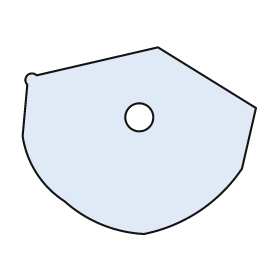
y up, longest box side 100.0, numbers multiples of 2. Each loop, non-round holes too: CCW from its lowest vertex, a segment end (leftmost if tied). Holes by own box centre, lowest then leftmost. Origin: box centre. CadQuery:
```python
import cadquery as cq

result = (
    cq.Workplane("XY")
    .moveTo(2.0, -40.0)
    .threePointArc((26.0, -30.0), (44.0, -12.0))
    .lineTo(50.0, 14.0)
    .lineTo(8.0, 40.0)
    .lineTo(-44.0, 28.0)
    .threePointArc((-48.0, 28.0), (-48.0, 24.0))
    .lineTo(-50.0, 2.0)
    .threePointArc((-44.0, -14.0), (-32.0, -26.0))
    .threePointArc((-16.0, -36.0), (2.0, -40.0))
    .close()
    .moveTo(0.0, 10.0)
    .circle(6.0)
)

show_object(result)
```